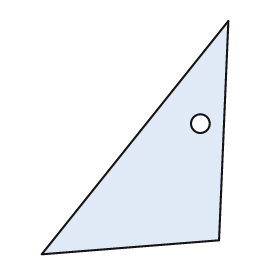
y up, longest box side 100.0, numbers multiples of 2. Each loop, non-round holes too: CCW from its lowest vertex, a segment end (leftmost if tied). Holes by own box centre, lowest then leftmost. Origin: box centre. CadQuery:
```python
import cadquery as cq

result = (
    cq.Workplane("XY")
    .moveTo(-40.0, -50.0)
    .lineTo(36.0, -44.0)
    .lineTo(40.0, 50.0)
    .close()
    .moveTo(28.0, 6.0)
    .circle(4.0)
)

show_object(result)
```